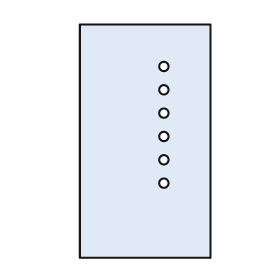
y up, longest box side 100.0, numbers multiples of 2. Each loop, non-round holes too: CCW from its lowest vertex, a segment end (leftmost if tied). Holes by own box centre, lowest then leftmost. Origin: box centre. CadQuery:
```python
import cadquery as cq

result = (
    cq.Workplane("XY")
    .moveTo(-28.0, -50.0)
    .lineTo(28.0, -50.0)
    .lineTo(28.0, 50.0)
    .lineTo(-28.0, 50.0)
    .close()
    .moveTo(8.0, -18.0)
    .circle(2.0)
    .moveTo(8.0, -8.0)
    .circle(2.0)
    .moveTo(8.0, 2.0)
    .circle(2.0)
    .moveTo(8.0, 12.0)
    .circle(2.0)
    .moveTo(8.0, 22.0)
    .circle(2.0)
    .moveTo(8.0, 32.0)
    .circle(2.0)
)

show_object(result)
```